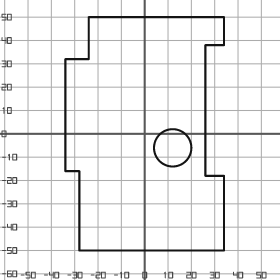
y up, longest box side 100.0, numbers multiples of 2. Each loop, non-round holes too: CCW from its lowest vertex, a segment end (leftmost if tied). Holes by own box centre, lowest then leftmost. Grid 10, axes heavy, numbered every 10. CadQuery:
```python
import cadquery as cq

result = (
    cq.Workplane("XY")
    .moveTo(-28.0, -50.0)
    .lineTo(34.0, -50.0)
    .lineTo(34.0, -18.0)
    .lineTo(26.0, -18.0)
    .lineTo(26.0, 38.0)
    .lineTo(34.0, 38.0)
    .lineTo(34.0, 50.0)
    .lineTo(-24.0, 50.0)
    .lineTo(-24.0, 32.0)
    .lineTo(-34.0, 32.0)
    .lineTo(-34.0, -16.0)
    .lineTo(-28.0, -16.0)
    .close()
    .moveTo(12.0, -6.0)
    .circle(8.0)
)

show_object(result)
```